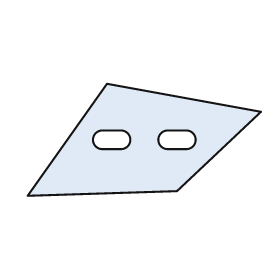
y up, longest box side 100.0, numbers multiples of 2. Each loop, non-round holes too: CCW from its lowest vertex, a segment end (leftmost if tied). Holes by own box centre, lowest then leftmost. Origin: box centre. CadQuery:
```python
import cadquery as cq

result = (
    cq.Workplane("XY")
    .moveTo(-50.0, -24.0)
    .lineTo(14.0, -22.0)
    .lineTo(50.0, 12.0)
    .lineTo(-16.0, 24.0)
    .close()
    .moveTo(-18.0, -4.0)
    .lineTo(-10.0, -4.0)
    .threePointArc((-6.0, 0.0), (-10.0, 4.0))
    .lineTo(-18.0, 4.0)
    .threePointArc((-22.0, 0.0), (-18.0, -4.0))
    .close()
    .moveTo(10.0, -4.0)
    .lineTo(18.0, -4.0)
    .threePointArc((22.0, 0.0), (18.0, 4.0))
    .lineTo(10.0, 4.0)
    .threePointArc((6.0, 0.0), (10.0, -4.0))
    .close()
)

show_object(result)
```